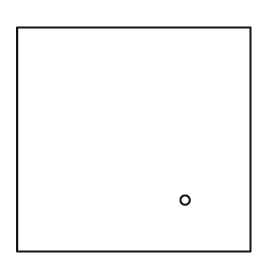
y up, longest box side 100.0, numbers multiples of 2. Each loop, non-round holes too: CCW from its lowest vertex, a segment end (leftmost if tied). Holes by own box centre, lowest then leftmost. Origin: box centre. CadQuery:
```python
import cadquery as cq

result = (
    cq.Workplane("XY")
    .moveTo(-50.0, -48.0)
    .lineTo(50.0, -48.0)
    .lineTo(50.0, 48.0)
    .lineTo(-50.0, 48.0)
    .close()
    .moveTo(22.0, -26.0)
    .circle(2.0)
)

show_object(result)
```